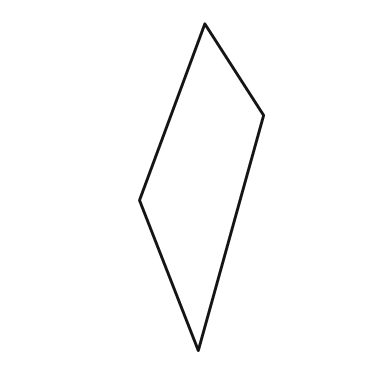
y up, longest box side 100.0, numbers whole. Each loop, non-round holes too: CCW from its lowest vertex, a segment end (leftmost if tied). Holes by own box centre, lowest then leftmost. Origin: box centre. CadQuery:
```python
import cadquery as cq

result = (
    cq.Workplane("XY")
    .moveTo(-1.0, -50.0)
    .lineTo(19.0, 22.0)
    .lineTo(1.0, 50.0)
    .lineTo(-19.0, -4.0)
    .close()
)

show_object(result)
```